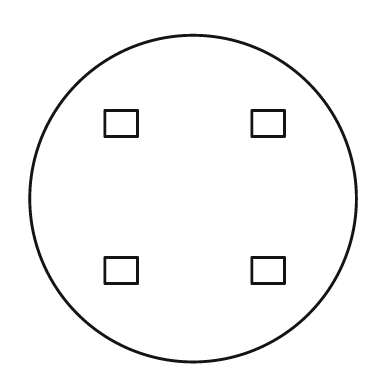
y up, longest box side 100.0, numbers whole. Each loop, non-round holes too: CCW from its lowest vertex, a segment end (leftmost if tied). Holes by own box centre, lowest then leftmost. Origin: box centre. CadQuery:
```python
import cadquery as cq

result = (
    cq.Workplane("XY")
    .moveTo(0.0, 0.0)
    .circle(50.0)
    .moveTo(-27.0, -26.0)
    .lineTo(-17.0, -26.0)
    .lineTo(-17.0, -18.0)
    .lineTo(-27.0, -18.0)
    .close()
    .moveTo(18.0, -26.0)
    .lineTo(28.0, -26.0)
    .lineTo(28.0, -18.0)
    .lineTo(18.0, -18.0)
    .close()
    .moveTo(-27.0, 19.0)
    .lineTo(-17.0, 19.0)
    .lineTo(-17.0, 27.0)
    .lineTo(-27.0, 27.0)
    .close()
    .moveTo(18.0, 19.0)
    .lineTo(28.0, 19.0)
    .lineTo(28.0, 27.0)
    .lineTo(18.0, 27.0)
    .close()
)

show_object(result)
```